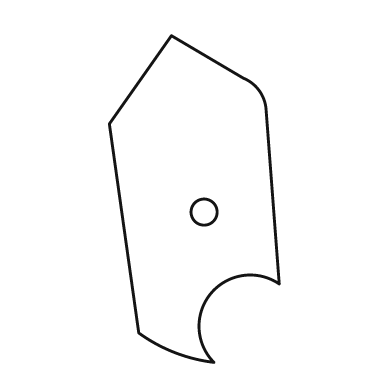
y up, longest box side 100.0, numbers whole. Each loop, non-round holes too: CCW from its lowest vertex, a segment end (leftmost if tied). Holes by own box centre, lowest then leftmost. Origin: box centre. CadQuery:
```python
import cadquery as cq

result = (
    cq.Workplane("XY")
    .moveTo(6.0, -50.0)
    .threePointArc((5.0, -29.0), (26.0, -26.0))
    .lineTo(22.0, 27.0)
    .threePointArc((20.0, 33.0), (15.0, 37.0))
    .lineTo(-7.0, 50.0)
    .lineTo(-26.0, 23.0)
    .lineTo(-17.0, -41.0)
    .threePointArc((-6.0, -47.0), (6.0, -50.0))
    .close()
    .moveTo(3.0, -4.0)
    .circle(4.0)
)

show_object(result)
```